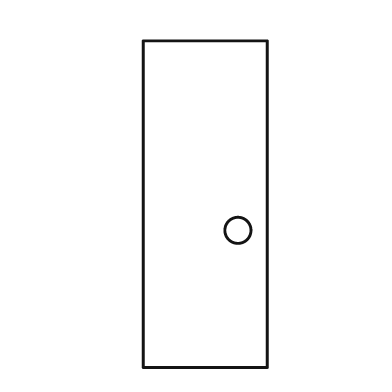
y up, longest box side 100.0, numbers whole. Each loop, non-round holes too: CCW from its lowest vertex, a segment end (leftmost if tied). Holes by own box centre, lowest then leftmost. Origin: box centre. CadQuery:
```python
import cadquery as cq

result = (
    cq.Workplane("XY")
    .moveTo(-19.0, -50.0)
    .lineTo(19.0, -50.0)
    .lineTo(19.0, 50.0)
    .lineTo(-19.0, 50.0)
    .close()
    .moveTo(10.0, -8.0)
    .circle(4.0)
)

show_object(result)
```